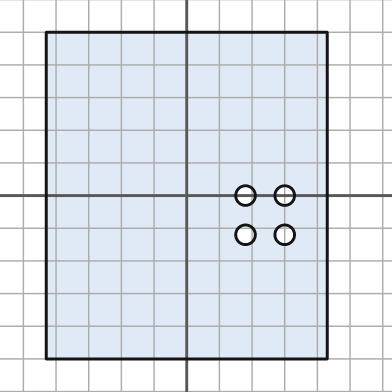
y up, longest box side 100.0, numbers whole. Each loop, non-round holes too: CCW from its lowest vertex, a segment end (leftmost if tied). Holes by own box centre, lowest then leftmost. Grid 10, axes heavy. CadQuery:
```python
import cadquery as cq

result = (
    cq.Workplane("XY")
    .moveTo(-43.0, -50.0)
    .lineTo(43.0, -50.0)
    .lineTo(43.0, 50.0)
    .lineTo(-43.0, 50.0)
    .close()
    .moveTo(18.0, -12.0)
    .circle(3.0)
    .moveTo(30.0, -12.0)
    .circle(3.0)
    .moveTo(18.0, 0.0)
    .circle(3.0)
    .moveTo(30.0, 0.0)
    .circle(3.0)
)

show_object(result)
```